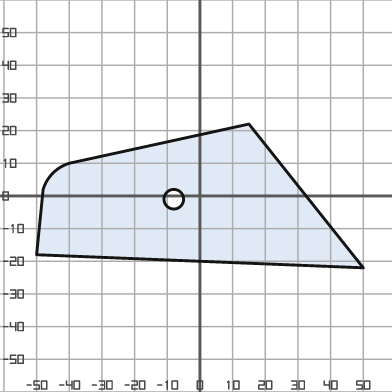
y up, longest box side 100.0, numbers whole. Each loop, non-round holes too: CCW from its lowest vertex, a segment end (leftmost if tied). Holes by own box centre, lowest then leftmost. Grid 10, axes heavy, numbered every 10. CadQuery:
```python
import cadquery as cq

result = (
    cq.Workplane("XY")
    .moveTo(50.0, -22.0)
    .lineTo(15.0, 22.0)
    .lineTo(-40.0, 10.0)
    .threePointArc((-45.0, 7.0), (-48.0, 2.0))
    .lineTo(-50.0, -18.0)
    .close()
    .moveTo(-8.0, -1.0)
    .circle(3.0)
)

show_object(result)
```